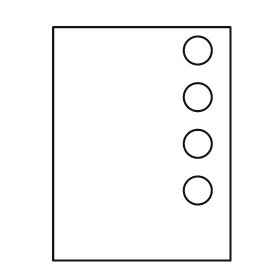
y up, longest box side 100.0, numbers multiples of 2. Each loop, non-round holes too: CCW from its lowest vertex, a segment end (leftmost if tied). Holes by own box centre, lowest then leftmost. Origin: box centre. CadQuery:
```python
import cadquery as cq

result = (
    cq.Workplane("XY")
    .moveTo(-38.0, -50.0)
    .lineTo(38.0, -50.0)
    .lineTo(38.0, 50.0)
    .lineTo(-38.0, 50.0)
    .close()
    .moveTo(24.0, -20.0)
    .circle(6.0)
    .moveTo(24.0, 0.0)
    .circle(6.0)
    .moveTo(24.0, 20.0)
    .circle(6.0)
    .moveTo(24.0, 40.0)
    .circle(6.0)
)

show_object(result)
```